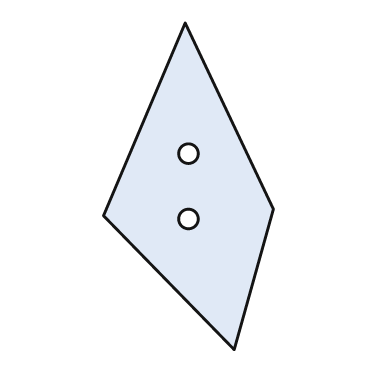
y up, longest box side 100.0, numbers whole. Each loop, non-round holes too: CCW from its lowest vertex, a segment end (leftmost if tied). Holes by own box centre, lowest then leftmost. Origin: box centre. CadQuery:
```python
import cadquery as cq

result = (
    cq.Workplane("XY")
    .moveTo(14.0, -50.0)
    .lineTo(26.0, -7.0)
    .lineTo(-1.0, 50.0)
    .lineTo(-26.0, -9.0)
    .close()
    .moveTo(0.0, -10.0)
    .circle(3.0)
    .moveTo(0.0, 10.0)
    .circle(3.0)
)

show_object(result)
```